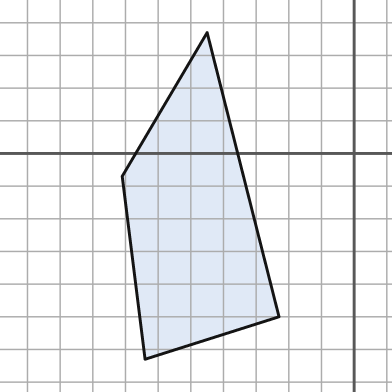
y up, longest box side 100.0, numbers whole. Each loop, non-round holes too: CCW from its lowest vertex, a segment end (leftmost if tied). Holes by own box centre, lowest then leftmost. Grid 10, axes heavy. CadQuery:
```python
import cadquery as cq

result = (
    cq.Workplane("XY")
    .moveTo(-64.0, -63.0)
    .lineTo(-23.0, -50.0)
    .lineTo(-45.0, 37.0)
    .lineTo(-71.0, -7.0)
    .close()
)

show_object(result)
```